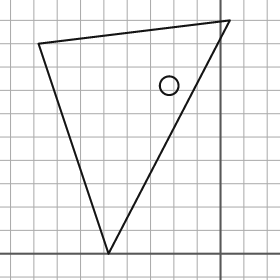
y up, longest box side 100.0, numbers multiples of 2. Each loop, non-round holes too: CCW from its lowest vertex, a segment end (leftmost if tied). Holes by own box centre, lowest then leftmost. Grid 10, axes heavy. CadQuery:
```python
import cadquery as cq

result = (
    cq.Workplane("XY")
    .moveTo(-48.0, 0.0)
    .lineTo(4.0, 100.0)
    .lineTo(-78.0, 90.0)
    .close()
    .moveTo(-22.0, 72.0)
    .circle(4.0)
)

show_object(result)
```